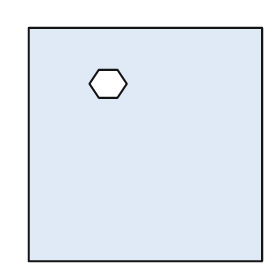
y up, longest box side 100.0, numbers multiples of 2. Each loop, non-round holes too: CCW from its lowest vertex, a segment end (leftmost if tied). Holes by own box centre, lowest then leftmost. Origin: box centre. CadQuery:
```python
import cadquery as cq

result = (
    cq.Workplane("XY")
    .moveTo(-50.0, -50.0)
    .lineTo(50.0, -50.0)
    .lineTo(50.0, 50.0)
    .lineTo(-50.0, 50.0)
    .close()
    .moveTo(-20.0, 20.0)
    .lineTo(-12.0, 20.0)
    .lineTo(-8.0, 26.0)
    .lineTo(-12.0, 32.0)
    .lineTo(-20.0, 32.0)
    .lineTo(-24.0, 26.0)
    .close()
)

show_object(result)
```